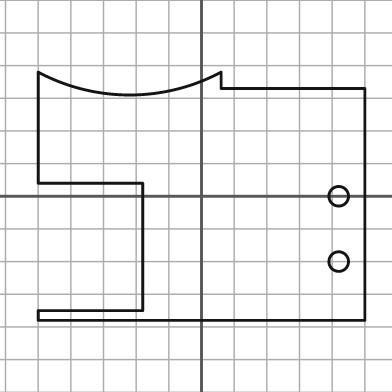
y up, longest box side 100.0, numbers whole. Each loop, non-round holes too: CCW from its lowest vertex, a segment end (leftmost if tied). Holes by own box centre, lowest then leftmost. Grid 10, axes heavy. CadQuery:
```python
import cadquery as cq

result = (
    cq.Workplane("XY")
    .moveTo(-50.0, -38.0)
    .lineTo(50.0, -38.0)
    .lineTo(50.0, 33.0)
    .lineTo(6.0, 33.0)
    .lineTo(6.0, 38.0)
    .threePointArc((-22.0, 31.0), (-50.0, 38.0))
    .lineTo(-50.0, 4.0)
    .lineTo(-18.0, 4.0)
    .lineTo(-18.0, -35.0)
    .lineTo(-50.0, -35.0)
    .close()
    .moveTo(42.0, -20.0)
    .circle(3.0)
    .moveTo(42.0, 0.0)
    .circle(3.0)
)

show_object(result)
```